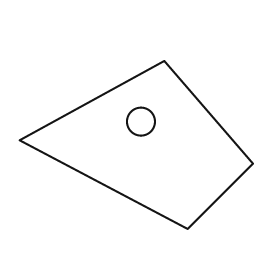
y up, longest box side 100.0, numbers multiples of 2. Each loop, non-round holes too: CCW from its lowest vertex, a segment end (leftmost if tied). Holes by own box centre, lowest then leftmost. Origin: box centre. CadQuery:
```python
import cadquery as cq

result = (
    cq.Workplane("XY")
    .moveTo(22.0, -36.0)
    .lineTo(50.0, -8.0)
    .lineTo(12.0, 36.0)
    .lineTo(-50.0, 2.0)
    .close()
    .moveTo(2.0, 10.0)
    .circle(6.0)
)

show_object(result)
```